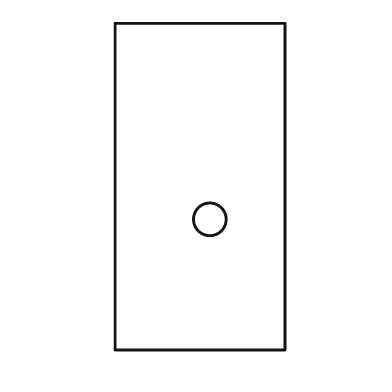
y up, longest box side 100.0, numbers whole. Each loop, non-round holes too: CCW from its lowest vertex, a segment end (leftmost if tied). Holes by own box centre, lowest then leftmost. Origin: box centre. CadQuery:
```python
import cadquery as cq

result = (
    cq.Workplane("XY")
    .moveTo(-26.0, -50.0)
    .lineTo(26.0, -50.0)
    .lineTo(26.0, 50.0)
    .lineTo(-26.0, 50.0)
    .close()
    .moveTo(3.0, -10.0)
    .circle(5.0)
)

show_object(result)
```